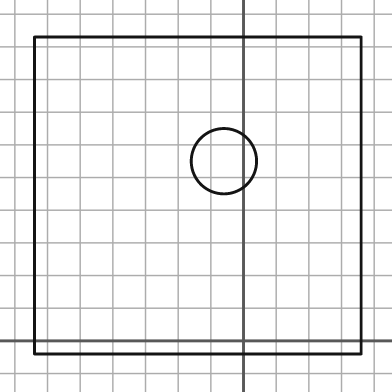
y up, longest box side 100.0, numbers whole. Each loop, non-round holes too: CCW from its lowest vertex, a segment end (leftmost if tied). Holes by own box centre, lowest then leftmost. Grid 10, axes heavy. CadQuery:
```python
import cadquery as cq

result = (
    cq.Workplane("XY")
    .moveTo(-64.0, -4.0)
    .lineTo(36.0, -4.0)
    .lineTo(36.0, 93.0)
    .lineTo(-64.0, 93.0)
    .close()
    .moveTo(-6.0, 55.0)
    .circle(10.0)
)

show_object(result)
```